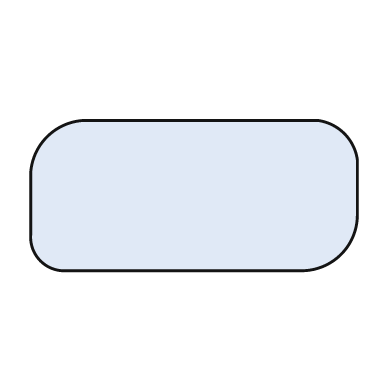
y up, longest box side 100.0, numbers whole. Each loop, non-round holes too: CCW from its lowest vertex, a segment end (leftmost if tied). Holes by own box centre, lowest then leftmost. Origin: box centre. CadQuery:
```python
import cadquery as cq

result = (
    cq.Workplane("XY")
    .moveTo(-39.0, -23.0)
    .lineTo(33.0, -23.0)
    .threePointArc((45.0, -18.0), (50.0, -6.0))
    .lineTo(50.0, 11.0)
    .threePointArc((46.0, 19.0), (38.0, 23.0))
    .lineTo(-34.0, 23.0)
    .threePointArc((-45.0, 18.0), (-50.0, 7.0))
    .lineTo(-50.0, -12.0)
    .threePointArc((-47.0, -20.0), (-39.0, -23.0))
    .close()
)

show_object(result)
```